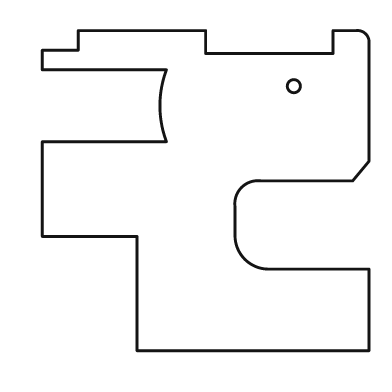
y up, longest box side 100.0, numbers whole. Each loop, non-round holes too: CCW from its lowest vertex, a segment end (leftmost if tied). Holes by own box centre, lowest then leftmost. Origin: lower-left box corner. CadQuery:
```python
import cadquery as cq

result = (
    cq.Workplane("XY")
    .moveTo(29.0, 0.0)
    .lineTo(100.0, 0.0)
    .lineTo(100.0, 25.0)
    .lineTo(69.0, 25.0)
    .threePointArc((62.0, 28.0), (59.0, 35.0))
    .lineTo(59.0, 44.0)
    .threePointArc((61.0, 50.0), (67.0, 52.0))
    .lineTo(95.0, 52.0)
    .lineTo(100.0, 58.0)
    .lineTo(100.0, 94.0)
    .threePointArc((99.0, 97.0), (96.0, 98.0))
    .lineTo(89.0, 98.0)
    .lineTo(89.0, 91.0)
    .lineTo(50.0, 91.0)
    .lineTo(50.0, 98.0)
    .lineTo(11.0, 98.0)
    .lineTo(11.0, 92.0)
    .lineTo(0.0, 92.0)
    .lineTo(0.0, 86.0)
    .lineTo(38.0, 86.0)
    .threePointArc((36.0, 75.0), (38.0, 64.0))
    .lineTo(0.0, 64.0)
    .lineTo(0.0, 35.0)
    .lineTo(29.0, 35.0)
    .close()
    .moveTo(77.0, 81.0)
    .circle(2.0)
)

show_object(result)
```